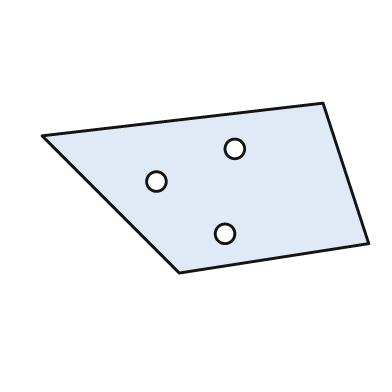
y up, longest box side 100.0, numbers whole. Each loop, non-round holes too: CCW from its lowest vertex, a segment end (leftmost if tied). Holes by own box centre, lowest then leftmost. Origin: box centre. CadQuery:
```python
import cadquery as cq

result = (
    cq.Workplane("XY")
    .moveTo(-8.0, -26.0)
    .lineTo(50.0, -17.0)
    .lineTo(36.0, 26.0)
    .lineTo(-50.0, 16.0)
    .close()
    .moveTo(6.0, -14.0)
    .circle(3.0)
    .moveTo(-15.0, 2.0)
    .circle(3.0)
    .moveTo(9.0, 12.0)
    .circle(3.0)
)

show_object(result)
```